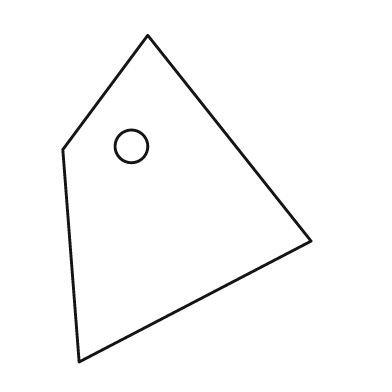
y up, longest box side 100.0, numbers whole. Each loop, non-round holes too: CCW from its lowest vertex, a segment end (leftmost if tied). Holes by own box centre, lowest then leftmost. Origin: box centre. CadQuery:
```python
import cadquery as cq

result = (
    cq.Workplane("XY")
    .moveTo(-33.0, -50.0)
    .lineTo(38.0, -13.0)
    .lineTo(-12.0, 50.0)
    .lineTo(-38.0, 15.0)
    .close()
    .moveTo(-17.0, 16.0)
    .circle(5.0)
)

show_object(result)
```